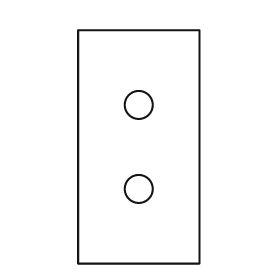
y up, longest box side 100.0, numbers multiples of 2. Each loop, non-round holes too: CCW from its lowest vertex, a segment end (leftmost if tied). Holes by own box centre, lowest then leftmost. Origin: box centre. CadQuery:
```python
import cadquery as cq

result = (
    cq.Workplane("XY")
    .moveTo(-26.0, -50.0)
    .lineTo(26.0, -50.0)
    .lineTo(26.0, 50.0)
    .lineTo(-26.0, 50.0)
    .close()
    .moveTo(0.0, -18.0)
    .circle(6.0)
    .moveTo(0.0, 18.0)
    .circle(6.0)
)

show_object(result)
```